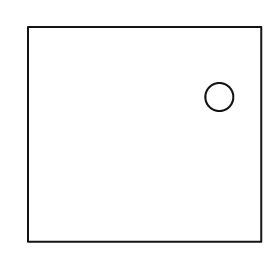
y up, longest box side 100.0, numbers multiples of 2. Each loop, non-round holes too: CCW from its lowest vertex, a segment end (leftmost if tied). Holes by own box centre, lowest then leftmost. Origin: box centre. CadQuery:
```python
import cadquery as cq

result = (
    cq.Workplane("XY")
    .moveTo(-50.0, -46.0)
    .lineTo(50.0, -46.0)
    .lineTo(50.0, 46.0)
    .lineTo(-50.0, 46.0)
    .close()
    .moveTo(32.0, 16.0)
    .circle(6.0)
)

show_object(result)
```